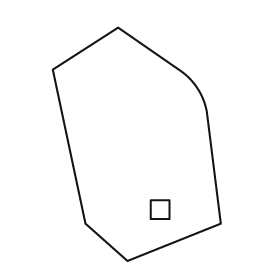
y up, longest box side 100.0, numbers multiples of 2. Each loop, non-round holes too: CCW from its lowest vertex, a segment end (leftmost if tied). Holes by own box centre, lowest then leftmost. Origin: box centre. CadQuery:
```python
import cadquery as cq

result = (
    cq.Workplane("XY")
    .moveTo(-4.0, -50.0)
    .lineTo(36.0, -34.0)
    .lineTo(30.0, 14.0)
    .threePointArc((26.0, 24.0), (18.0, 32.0))
    .lineTo(-8.0, 50.0)
    .lineTo(-36.0, 32.0)
    .lineTo(-22.0, -34.0)
    .close()
    .moveTo(6.0, -32.0)
    .lineTo(14.0, -32.0)
    .lineTo(14.0, -24.0)
    .lineTo(6.0, -24.0)
    .close()
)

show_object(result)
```